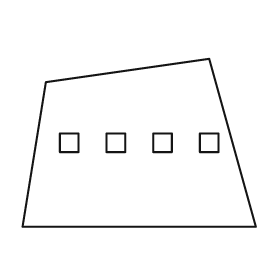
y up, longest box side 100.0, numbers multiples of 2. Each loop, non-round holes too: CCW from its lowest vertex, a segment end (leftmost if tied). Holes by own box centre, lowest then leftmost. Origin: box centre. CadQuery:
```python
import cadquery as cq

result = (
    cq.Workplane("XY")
    .moveTo(-50.0, -36.0)
    .lineTo(50.0, -36.0)
    .lineTo(30.0, 36.0)
    .lineTo(-40.0, 26.0)
    .close()
    .moveTo(-34.0, -4.0)
    .lineTo(-26.0, -4.0)
    .lineTo(-26.0, 4.0)
    .lineTo(-34.0, 4.0)
    .close()
    .moveTo(-14.0, -4.0)
    .lineTo(-6.0, -4.0)
    .lineTo(-6.0, 4.0)
    .lineTo(-14.0, 4.0)
    .close()
    .moveTo(6.0, -4.0)
    .lineTo(14.0, -4.0)
    .lineTo(14.0, 4.0)
    .lineTo(6.0, 4.0)
    .close()
    .moveTo(26.0, -4.0)
    .lineTo(34.0, -4.0)
    .lineTo(34.0, 4.0)
    .lineTo(26.0, 4.0)
    .close()
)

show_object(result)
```